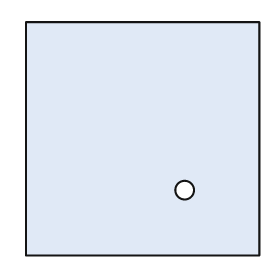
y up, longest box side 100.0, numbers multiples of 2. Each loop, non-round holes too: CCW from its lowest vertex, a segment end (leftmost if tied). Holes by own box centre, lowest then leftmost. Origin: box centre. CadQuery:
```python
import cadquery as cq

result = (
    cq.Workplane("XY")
    .moveTo(-50.0, -50.0)
    .lineTo(50.0, -50.0)
    .lineTo(50.0, 50.0)
    .lineTo(-50.0, 50.0)
    .close()
    .moveTo(18.0, -22.0)
    .circle(4.0)
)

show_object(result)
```